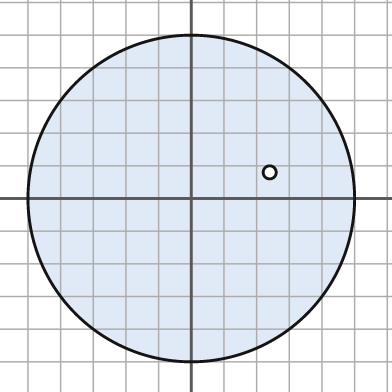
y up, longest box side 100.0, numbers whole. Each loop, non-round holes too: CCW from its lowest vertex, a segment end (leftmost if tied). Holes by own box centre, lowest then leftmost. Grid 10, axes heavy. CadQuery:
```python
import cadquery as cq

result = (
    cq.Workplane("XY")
    .moveTo(0.0, 0.0)
    .circle(50.0)
    .moveTo(24.0, 8.0)
    .circle(2.0)
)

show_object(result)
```